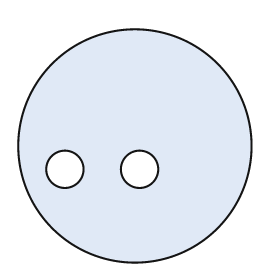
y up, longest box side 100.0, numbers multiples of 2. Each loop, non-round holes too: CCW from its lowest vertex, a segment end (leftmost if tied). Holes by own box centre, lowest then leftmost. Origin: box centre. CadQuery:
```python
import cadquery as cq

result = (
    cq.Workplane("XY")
    .moveTo(0.0, 0.0)
    .circle(50.0)
    .moveTo(-30.0, -10.0)
    .circle(8.0)
    .moveTo(2.0, -10.0)
    .circle(8.0)
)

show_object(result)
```